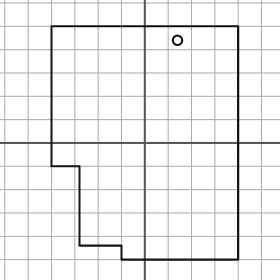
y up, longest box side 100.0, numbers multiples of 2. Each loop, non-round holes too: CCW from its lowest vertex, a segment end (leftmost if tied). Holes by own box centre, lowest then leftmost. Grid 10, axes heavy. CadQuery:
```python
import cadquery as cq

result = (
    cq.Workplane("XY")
    .moveTo(-10.0, -50.0)
    .lineTo(40.0, -50.0)
    .lineTo(40.0, 50.0)
    .lineTo(-40.0, 50.0)
    .lineTo(-40.0, -10.0)
    .lineTo(-28.0, -10.0)
    .lineTo(-28.0, -44.0)
    .lineTo(-10.0, -44.0)
    .close()
    .moveTo(14.0, 44.0)
    .circle(2.0)
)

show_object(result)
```